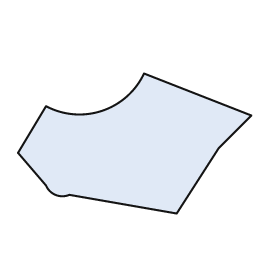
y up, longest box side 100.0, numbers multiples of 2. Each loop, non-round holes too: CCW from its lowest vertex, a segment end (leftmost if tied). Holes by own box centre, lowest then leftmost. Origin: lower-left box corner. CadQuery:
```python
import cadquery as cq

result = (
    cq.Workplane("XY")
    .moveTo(68.0, 0.0)
    .lineTo(86.0, 28.0)
    .lineTo(100.0, 42.0)
    .lineTo(54.0, 60.0)
    .threePointArc((36.0, 44.0), (12.0, 46.0))
    .lineTo(0.0, 26.0)
    .lineTo(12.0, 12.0)
    .threePointArc((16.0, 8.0), (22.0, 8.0))
    .close()
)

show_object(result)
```